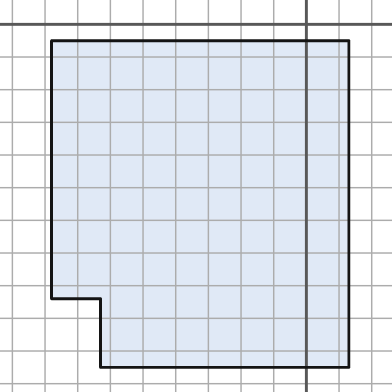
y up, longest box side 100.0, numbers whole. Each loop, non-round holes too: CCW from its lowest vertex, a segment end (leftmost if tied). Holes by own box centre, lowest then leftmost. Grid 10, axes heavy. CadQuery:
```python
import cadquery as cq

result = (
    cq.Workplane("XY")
    .moveTo(-63.0, -105.0)
    .lineTo(13.0, -105.0)
    .lineTo(13.0, -5.0)
    .lineTo(-78.0, -5.0)
    .lineTo(-78.0, -84.0)
    .lineTo(-63.0, -84.0)
    .close()
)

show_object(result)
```